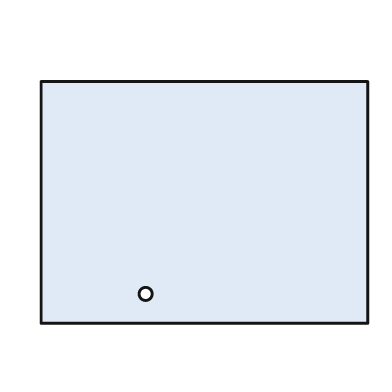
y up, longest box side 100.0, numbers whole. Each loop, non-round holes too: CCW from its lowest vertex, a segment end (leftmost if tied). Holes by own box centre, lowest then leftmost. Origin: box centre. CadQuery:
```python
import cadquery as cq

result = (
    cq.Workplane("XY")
    .moveTo(-50.0, -37.0)
    .lineTo(50.0, -37.0)
    .lineTo(50.0, 37.0)
    .lineTo(-50.0, 37.0)
    .close()
    .moveTo(-18.0, -28.0)
    .circle(2.0)
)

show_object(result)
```